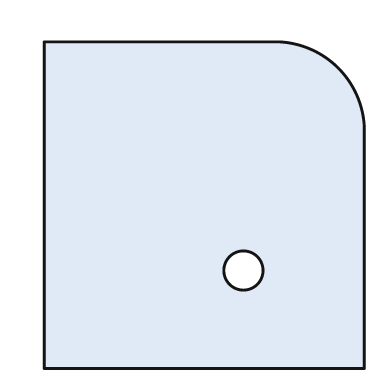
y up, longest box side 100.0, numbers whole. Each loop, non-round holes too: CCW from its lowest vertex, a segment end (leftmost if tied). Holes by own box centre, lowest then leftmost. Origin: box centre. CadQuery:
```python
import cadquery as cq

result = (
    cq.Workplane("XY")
    .moveTo(-49.0, -50.0)
    .lineTo(49.0, -50.0)
    .lineTo(49.0, 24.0)
    .threePointArc((41.0, 42.0), (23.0, 50.0))
    .lineTo(-49.0, 50.0)
    .close()
    .moveTo(12.0, -20.0)
    .circle(6.0)
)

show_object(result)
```